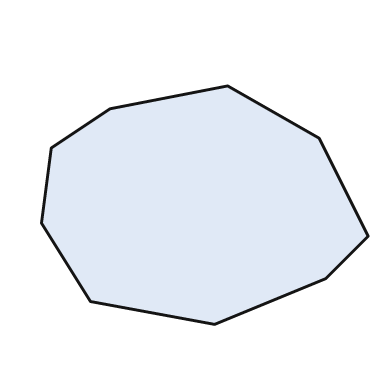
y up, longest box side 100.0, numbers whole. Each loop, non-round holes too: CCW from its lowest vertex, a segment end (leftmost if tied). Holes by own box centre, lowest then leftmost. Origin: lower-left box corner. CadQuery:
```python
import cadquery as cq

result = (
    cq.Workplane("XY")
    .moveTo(53.0, 0.0)
    .lineTo(87.0, 14.0)
    .lineTo(100.0, 27.0)
    .lineTo(85.0, 57.0)
    .lineTo(57.0, 73.0)
    .lineTo(21.0, 66.0)
    .lineTo(3.0, 54.0)
    .lineTo(0.0, 31.0)
    .lineTo(15.0, 7.0)
    .close()
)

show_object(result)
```